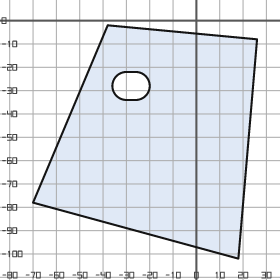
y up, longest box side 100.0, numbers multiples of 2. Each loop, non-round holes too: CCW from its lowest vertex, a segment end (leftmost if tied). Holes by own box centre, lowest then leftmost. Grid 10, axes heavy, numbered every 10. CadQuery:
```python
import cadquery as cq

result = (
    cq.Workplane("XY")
    .moveTo(18.0, -102.0)
    .lineTo(26.0, -8.0)
    .lineTo(-38.0, -2.0)
    .lineTo(-70.0, -78.0)
    .close()
    .moveTo(-30.0, -34.0)
    .lineTo(-26.0, -34.0)
    .threePointArc((-20.0, -28.0), (-26.0, -22.0))
    .lineTo(-30.0, -22.0)
    .threePointArc((-36.0, -28.0), (-30.0, -34.0))
    .close()
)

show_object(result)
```